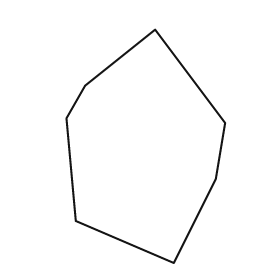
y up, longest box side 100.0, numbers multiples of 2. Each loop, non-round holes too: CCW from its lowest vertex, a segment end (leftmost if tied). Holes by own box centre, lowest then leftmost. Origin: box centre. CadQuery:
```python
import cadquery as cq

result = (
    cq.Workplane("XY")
    .moveTo(12.0, -50.0)
    .lineTo(30.0, -14.0)
    .lineTo(34.0, 10.0)
    .lineTo(4.0, 50.0)
    .lineTo(-26.0, 26.0)
    .lineTo(-34.0, 12.0)
    .lineTo(-30.0, -32.0)
    .close()
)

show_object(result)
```